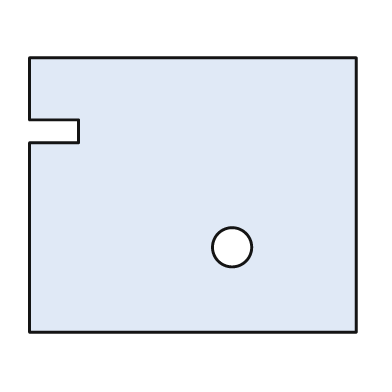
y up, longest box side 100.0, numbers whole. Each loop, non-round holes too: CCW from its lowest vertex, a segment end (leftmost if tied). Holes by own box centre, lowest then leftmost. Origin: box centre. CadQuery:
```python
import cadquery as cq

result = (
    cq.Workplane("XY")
    .moveTo(-50.0, -42.0)
    .lineTo(50.0, -42.0)
    .lineTo(50.0, 42.0)
    .lineTo(-50.0, 42.0)
    .lineTo(-50.0, 23.0)
    .lineTo(-35.0, 23.0)
    .lineTo(-35.0, 16.0)
    .lineTo(-50.0, 16.0)
    .close()
    .moveTo(12.0, -16.0)
    .circle(6.0)
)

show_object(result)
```